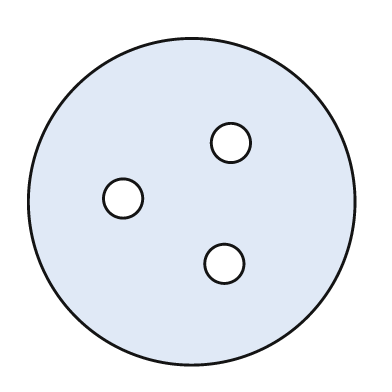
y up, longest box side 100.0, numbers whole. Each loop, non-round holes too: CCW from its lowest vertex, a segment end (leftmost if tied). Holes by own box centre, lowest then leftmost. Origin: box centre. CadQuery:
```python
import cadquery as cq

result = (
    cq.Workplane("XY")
    .moveTo(0.0, 0.0)
    .circle(50.0)
    .moveTo(10.0, -19.0)
    .circle(6.0)
    .moveTo(-21.0, 1.0)
    .circle(6.0)
    .moveTo(12.0, 18.0)
    .circle(6.0)
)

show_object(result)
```